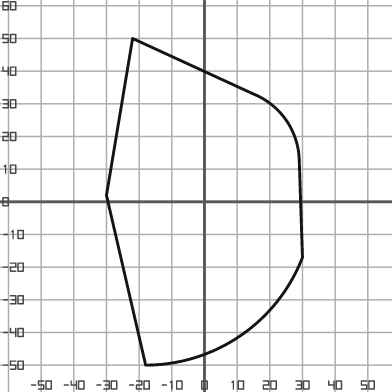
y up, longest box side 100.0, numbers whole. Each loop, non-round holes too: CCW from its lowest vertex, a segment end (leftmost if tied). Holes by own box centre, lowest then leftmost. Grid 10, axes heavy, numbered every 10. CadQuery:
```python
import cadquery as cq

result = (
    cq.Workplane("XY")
    .moveTo(-18.0, -50.0)
    .threePointArc((11.0, -41.0), (30.0, -17.0))
    .lineTo(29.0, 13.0)
    .threePointArc((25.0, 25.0), (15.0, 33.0))
    .lineTo(-22.0, 50.0)
    .lineTo(-30.0, 2.0)
    .close()
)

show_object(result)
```